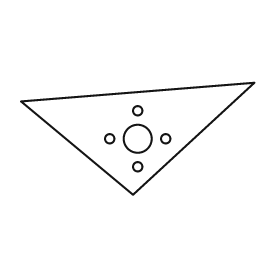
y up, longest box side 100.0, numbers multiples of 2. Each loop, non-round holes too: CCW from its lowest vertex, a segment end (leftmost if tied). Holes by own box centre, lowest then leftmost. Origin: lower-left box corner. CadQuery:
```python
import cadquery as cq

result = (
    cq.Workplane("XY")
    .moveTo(48.0, 0.0)
    .lineTo(100.0, 48.0)
    .lineTo(0.0, 40.0)
    .close()
    .moveTo(50.0, 12.0)
    .circle(2.0)
    .moveTo(38.0, 24.0)
    .circle(2.0)
    .moveTo(50.0, 24.0)
    .circle(6.0)
    .moveTo(62.0, 24.0)
    .circle(2.0)
    .moveTo(50.0, 36.0)
    .circle(2.0)
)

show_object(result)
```